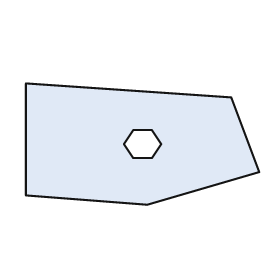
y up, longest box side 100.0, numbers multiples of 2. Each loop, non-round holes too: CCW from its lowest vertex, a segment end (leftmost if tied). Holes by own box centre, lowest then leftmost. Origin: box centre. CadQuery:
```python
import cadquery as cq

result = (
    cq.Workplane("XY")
    .moveTo(2.0, -26.0)
    .lineTo(50.0, -12.0)
    .lineTo(38.0, 20.0)
    .lineTo(-50.0, 26.0)
    .lineTo(-50.0, -22.0)
    .close()
    .moveTo(-4.0, -6.0)
    .lineTo(4.0, -6.0)
    .lineTo(8.0, 0.0)
    .lineTo(4.0, 6.0)
    .lineTo(-4.0, 6.0)
    .lineTo(-8.0, 0.0)
    .close()
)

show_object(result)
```